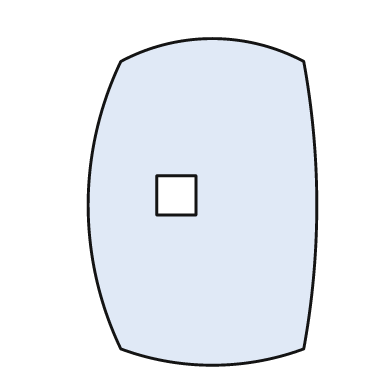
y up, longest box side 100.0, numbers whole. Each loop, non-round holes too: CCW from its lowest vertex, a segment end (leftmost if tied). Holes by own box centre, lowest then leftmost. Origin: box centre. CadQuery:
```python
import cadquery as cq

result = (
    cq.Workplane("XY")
    .moveTo(-25.0, -45.0)
    .threePointArc((3.0, -50.0), (31.0, -45.0))
    .threePointArc((35.0, -1.0), (31.0, 43.0))
    .threePointArc((3.0, 50.0), (-25.0, 43.0))
    .threePointArc((-35.0, -1.0), (-25.0, -45.0))
    .close()
    .moveTo(-14.0, -4.0)
    .lineTo(-2.0, -4.0)
    .lineTo(-2.0, 8.0)
    .lineTo(-14.0, 8.0)
    .close()
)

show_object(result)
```